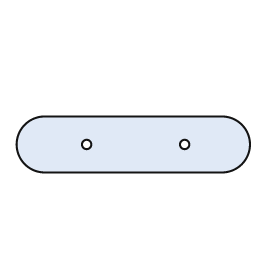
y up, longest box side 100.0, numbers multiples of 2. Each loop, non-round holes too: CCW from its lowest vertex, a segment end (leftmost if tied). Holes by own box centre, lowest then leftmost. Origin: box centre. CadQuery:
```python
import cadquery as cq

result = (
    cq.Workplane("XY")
    .moveTo(-38.0, -12.0)
    .lineTo(38.0, -12.0)
    .threePointArc((50.0, 0.0), (38.0, 12.0))
    .lineTo(-38.0, 12.0)
    .threePointArc((-50.0, 0.0), (-38.0, -12.0))
    .close()
    .moveTo(-20.0, 0.0)
    .circle(2.0)
    .moveTo(22.0, 0.0)
    .circle(2.0)
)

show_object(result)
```